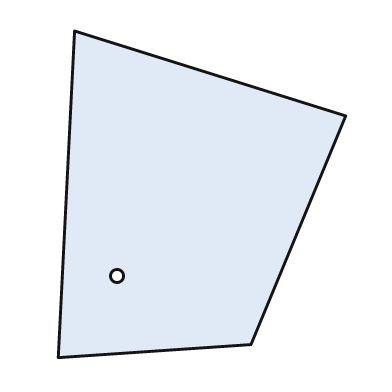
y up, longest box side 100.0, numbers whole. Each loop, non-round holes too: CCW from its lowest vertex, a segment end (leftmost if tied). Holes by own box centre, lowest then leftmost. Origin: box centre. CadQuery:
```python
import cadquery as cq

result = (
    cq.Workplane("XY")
    .moveTo(-44.0, -50.0)
    .lineTo(15.0, -46.0)
    .lineTo(44.0, 24.0)
    .lineTo(-39.0, 50.0)
    .close()
    .moveTo(-26.0, -25.0)
    .circle(2.0)
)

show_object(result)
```